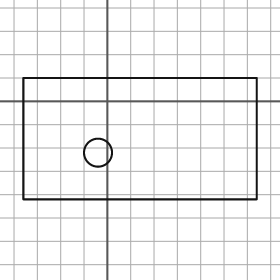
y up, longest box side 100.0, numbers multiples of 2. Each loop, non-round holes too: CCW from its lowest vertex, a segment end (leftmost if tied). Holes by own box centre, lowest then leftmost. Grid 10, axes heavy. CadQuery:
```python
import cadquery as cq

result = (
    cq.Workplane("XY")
    .moveTo(-36.0, -42.0)
    .lineTo(64.0, -42.0)
    .lineTo(64.0, 10.0)
    .lineTo(-36.0, 10.0)
    .close()
    .moveTo(-4.0, -22.0)
    .circle(6.0)
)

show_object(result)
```